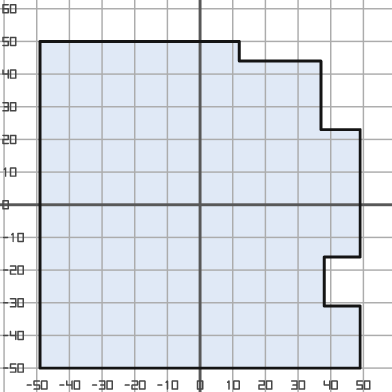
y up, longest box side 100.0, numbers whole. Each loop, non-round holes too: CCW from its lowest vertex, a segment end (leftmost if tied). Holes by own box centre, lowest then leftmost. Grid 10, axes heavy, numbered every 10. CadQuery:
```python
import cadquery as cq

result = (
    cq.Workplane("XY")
    .moveTo(-49.0, -50.0)
    .lineTo(49.0, -50.0)
    .lineTo(49.0, -31.0)
    .lineTo(38.0, -31.0)
    .lineTo(38.0, -16.0)
    .lineTo(49.0, -16.0)
    .lineTo(49.0, 23.0)
    .lineTo(37.0, 23.0)
    .lineTo(37.0, 44.0)
    .lineTo(12.0, 44.0)
    .lineTo(12.0, 50.0)
    .lineTo(-49.0, 50.0)
    .close()
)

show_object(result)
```